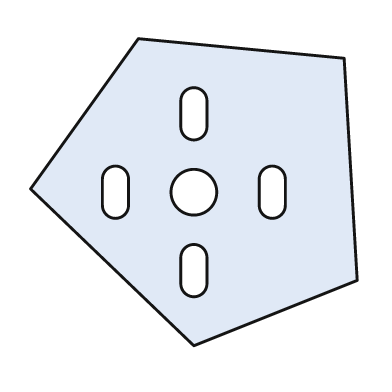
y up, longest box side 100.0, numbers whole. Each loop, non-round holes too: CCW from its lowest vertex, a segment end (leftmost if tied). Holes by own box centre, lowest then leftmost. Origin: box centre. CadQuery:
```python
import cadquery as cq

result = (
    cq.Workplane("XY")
    .moveTo(0.0, -47.0)
    .lineTo(50.0, -27.0)
    .lineTo(46.0, 41.0)
    .lineTo(-17.0, 47.0)
    .lineTo(-50.0, 1.0)
    .close()
    .moveTo(-4.0, -28.0)
    .threePointArc((0.0, -32.0), (4.0, -28.0))
    .lineTo(4.0, -20.0)
    .threePointArc((0.0, -16.0), (-4.0, -20.0))
    .close()
    .moveTo(-28.0, -4.0)
    .threePointArc((-24.0, -8.0), (-20.0, -4.0))
    .lineTo(-20.0, 4.0)
    .threePointArc((-24.0, 8.0), (-28.0, 4.0))
    .close()
    .moveTo(0.0, 0.0)
    .circle(7.0)
    .moveTo(20.0, -4.0)
    .threePointArc((24.0, -8.0), (28.0, -4.0))
    .lineTo(28.0, 4.0)
    .threePointArc((24.0, 8.0), (20.0, 4.0))
    .close()
    .moveTo(-4.0, 20.0)
    .threePointArc((0.0, 16.0), (4.0, 20.0))
    .lineTo(4.0, 28.0)
    .threePointArc((0.0, 32.0), (-4.0, 28.0))
    .close()
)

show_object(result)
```